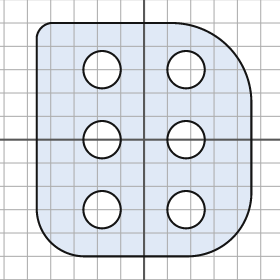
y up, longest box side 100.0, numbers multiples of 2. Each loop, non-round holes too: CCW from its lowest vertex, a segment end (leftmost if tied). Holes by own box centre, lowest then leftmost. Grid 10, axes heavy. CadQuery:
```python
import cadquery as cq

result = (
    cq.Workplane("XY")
    .moveTo(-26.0, -50.0)
    .lineTo(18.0, -50.0)
    .threePointArc((38.0, -42.0), (46.0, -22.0))
    .lineTo(46.0, 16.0)
    .threePointArc((36.0, 40.0), (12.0, 50.0))
    .lineTo(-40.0, 50.0)
    .threePointArc((-44.0, 48.0), (-46.0, 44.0))
    .lineTo(-46.0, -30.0)
    .threePointArc((-40.0, -44.0), (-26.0, -50.0))
    .close()
    .moveTo(-18.0, -30.0)
    .circle(8.0)
    .moveTo(18.0, -30.0)
    .circle(8.0)
    .moveTo(-18.0, 0.0)
    .circle(8.0)
    .moveTo(18.0, 0.0)
    .circle(8.0)
    .moveTo(-18.0, 30.0)
    .circle(8.0)
    .moveTo(18.0, 30.0)
    .circle(8.0)
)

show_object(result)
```